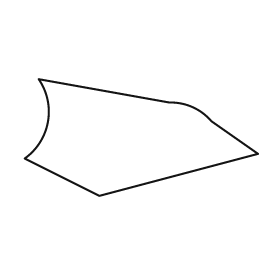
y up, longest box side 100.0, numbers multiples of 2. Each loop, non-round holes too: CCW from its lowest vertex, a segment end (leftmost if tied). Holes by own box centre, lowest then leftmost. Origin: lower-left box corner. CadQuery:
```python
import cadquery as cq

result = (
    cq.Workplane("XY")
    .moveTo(32.0, 0.0)
    .lineTo(100.0, 18.0)
    .lineTo(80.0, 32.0)
    .threePointArc((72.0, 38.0), (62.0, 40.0))
    .lineTo(6.0, 50.0)
    .threePointArc((10.0, 32.0), (0.0, 16.0))
    .close()
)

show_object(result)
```